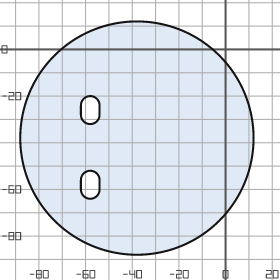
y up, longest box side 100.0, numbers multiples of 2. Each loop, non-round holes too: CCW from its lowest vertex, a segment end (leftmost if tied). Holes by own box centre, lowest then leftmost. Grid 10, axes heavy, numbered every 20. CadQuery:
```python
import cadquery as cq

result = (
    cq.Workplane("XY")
    .moveTo(-38.0, -38.0)
    .circle(50.0)
    .moveTo(-62.0, -60.0)
    .threePointArc((-58.0, -64.0), (-54.0, -60.0))
    .lineTo(-54.0, -56.0)
    .threePointArc((-58.0, -52.0), (-62.0, -56.0))
    .close()
    .moveTo(-62.0, -28.0)
    .threePointArc((-58.0, -32.0), (-54.0, -28.0))
    .lineTo(-54.0, -24.0)
    .threePointArc((-58.0, -20.0), (-62.0, -24.0))
    .close()
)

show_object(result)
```